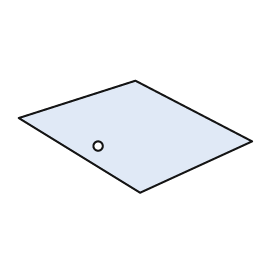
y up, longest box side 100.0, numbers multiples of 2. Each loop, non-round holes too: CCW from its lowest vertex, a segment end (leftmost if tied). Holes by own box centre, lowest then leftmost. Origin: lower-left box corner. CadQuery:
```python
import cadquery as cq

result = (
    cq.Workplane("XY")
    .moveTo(52.0, 0.0)
    .lineTo(100.0, 22.0)
    .lineTo(50.0, 48.0)
    .lineTo(0.0, 32.0)
    .close()
    .moveTo(34.0, 20.0)
    .circle(2.0)
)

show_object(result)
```